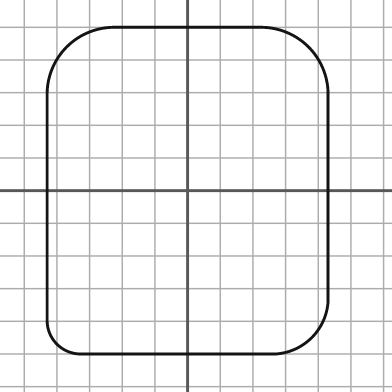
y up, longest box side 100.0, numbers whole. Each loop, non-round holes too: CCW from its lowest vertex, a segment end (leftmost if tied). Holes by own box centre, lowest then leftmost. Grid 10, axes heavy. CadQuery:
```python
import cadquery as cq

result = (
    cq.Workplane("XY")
    .moveTo(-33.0, -50.0)
    .lineTo(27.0, -50.0)
    .threePointArc((38.0, -45.0), (43.0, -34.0))
    .lineTo(43.0, 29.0)
    .threePointArc((37.0, 44.0), (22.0, 50.0))
    .lineTo(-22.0, 50.0)
    .threePointArc((-37.0, 44.0), (-43.0, 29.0))
    .lineTo(-43.0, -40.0)
    .threePointArc((-40.0, -47.0), (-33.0, -50.0))
    .close()
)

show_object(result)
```